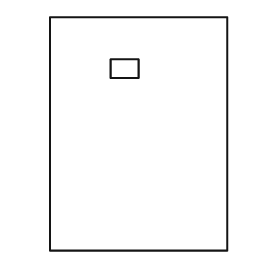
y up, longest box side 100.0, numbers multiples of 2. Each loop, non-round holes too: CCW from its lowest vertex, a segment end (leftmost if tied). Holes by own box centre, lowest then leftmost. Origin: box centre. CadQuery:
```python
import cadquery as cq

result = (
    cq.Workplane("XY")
    .moveTo(-38.0, -50.0)
    .lineTo(38.0, -50.0)
    .lineTo(38.0, 50.0)
    .lineTo(-38.0, 50.0)
    .close()
    .moveTo(-12.0, 24.0)
    .lineTo(0.0, 24.0)
    .lineTo(0.0, 32.0)
    .lineTo(-12.0, 32.0)
    .close()
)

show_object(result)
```